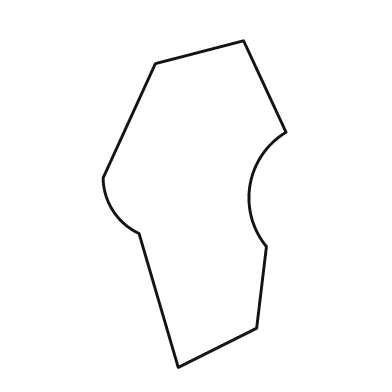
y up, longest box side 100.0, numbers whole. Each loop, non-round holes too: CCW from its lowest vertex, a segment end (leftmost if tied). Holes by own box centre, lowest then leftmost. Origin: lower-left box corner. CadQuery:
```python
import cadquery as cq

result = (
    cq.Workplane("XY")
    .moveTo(23.0, 0.0)
    .lineTo(47.0, 12.0)
    .lineTo(50.0, 37.0)
    .threePointArc((45.0, 56.0), (56.0, 72.0))
    .lineTo(43.0, 100.0)
    .lineTo(16.0, 93.0)
    .lineTo(0.0, 58.0)
    .threePointArc((3.0, 48.0), (11.0, 41.0))
    .close()
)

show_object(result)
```